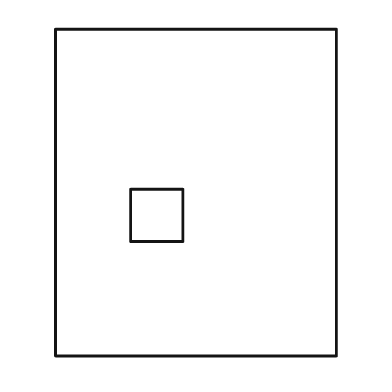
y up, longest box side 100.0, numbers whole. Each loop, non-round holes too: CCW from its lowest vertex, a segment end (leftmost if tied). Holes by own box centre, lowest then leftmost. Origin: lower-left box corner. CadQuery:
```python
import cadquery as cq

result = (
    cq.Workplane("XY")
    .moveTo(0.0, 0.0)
    .lineTo(86.0, 0.0)
    .lineTo(86.0, 100.0)
    .lineTo(0.0, 100.0)
    .close()
    .moveTo(23.0, 35.0)
    .lineTo(39.0, 35.0)
    .lineTo(39.0, 51.0)
    .lineTo(23.0, 51.0)
    .close()
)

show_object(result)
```